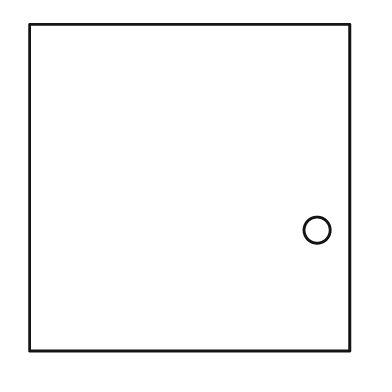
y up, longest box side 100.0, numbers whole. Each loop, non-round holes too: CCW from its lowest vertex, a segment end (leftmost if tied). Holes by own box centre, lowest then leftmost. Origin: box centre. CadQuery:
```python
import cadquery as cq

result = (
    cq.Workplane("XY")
    .moveTo(-49.0, -50.0)
    .lineTo(49.0, -50.0)
    .lineTo(49.0, 50.0)
    .lineTo(-49.0, 50.0)
    .close()
    .moveTo(39.0, -13.0)
    .circle(4.0)
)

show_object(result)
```